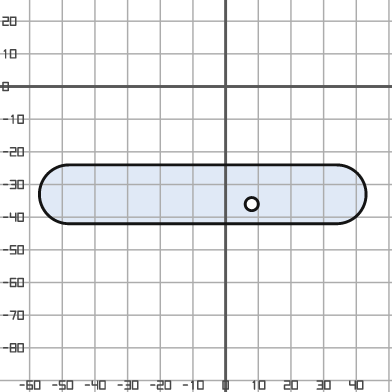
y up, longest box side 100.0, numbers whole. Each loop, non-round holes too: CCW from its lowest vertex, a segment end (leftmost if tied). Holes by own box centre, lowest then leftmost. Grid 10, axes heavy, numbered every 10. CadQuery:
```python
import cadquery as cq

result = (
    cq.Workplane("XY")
    .moveTo(-48.0, -42.0)
    .lineTo(34.0, -42.0)
    .threePointArc((43.0, -33.0), (34.0, -24.0))
    .lineTo(-48.0, -24.0)
    .threePointArc((-57.0, -33.0), (-48.0, -42.0))
    .close()
    .moveTo(8.0, -36.0)
    .circle(2.0)
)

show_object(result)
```